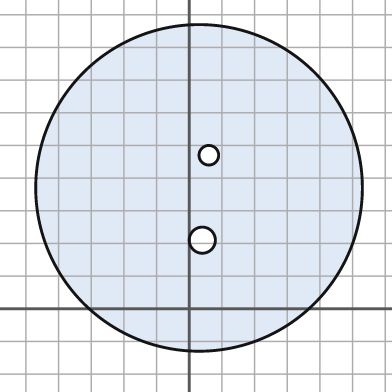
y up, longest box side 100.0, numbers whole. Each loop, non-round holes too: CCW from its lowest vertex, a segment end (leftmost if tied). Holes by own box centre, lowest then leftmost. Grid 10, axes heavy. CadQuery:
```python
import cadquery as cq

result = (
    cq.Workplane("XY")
    .moveTo(3.0, 37.0)
    .circle(50.0)
    .moveTo(4.0, 21.0)
    .circle(4.0)
    .moveTo(6.0, 47.0)
    .circle(3.0)
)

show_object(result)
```